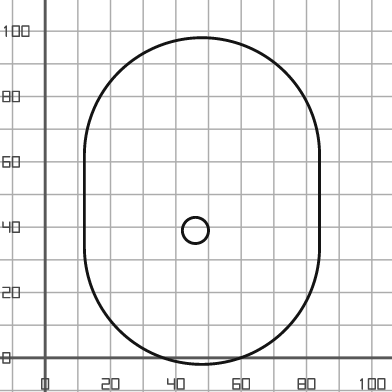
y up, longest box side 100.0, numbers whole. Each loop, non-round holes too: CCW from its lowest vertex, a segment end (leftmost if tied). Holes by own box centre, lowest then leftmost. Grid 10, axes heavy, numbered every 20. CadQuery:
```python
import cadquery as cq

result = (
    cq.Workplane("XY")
    .moveTo(12.0, 34.0)
    .threePointArc((48.0, -2.0), (84.0, 34.0))
    .lineTo(84.0, 62.0)
    .threePointArc((48.0, 98.0), (12.0, 62.0))
    .close()
    .moveTo(46.0, 39.0)
    .circle(4.0)
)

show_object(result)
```